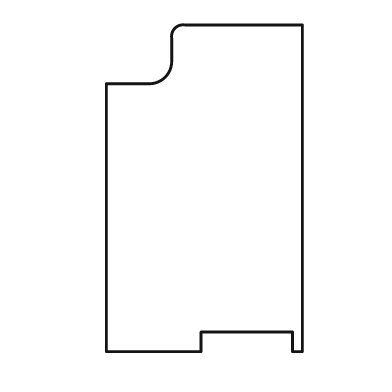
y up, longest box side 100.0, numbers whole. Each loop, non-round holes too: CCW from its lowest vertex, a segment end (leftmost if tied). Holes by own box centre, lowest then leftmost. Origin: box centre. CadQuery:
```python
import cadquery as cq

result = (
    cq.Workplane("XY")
    .moveTo(-30.0, -50.0)
    .lineTo(-1.0, -50.0)
    .lineTo(-1.0, -44.0)
    .lineTo(27.0, -44.0)
    .lineTo(27.0, -50.0)
    .lineTo(30.0, -50.0)
    .lineTo(30.0, 50.0)
    .lineTo(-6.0, 50.0)
    .threePointArc((-9.0, 49.0), (-10.0, 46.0))
    .lineTo(-10.0, 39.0)
    .threePointArc((-12.0, 34.0), (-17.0, 32.0))
    .lineTo(-30.0, 32.0)
    .close()
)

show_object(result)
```